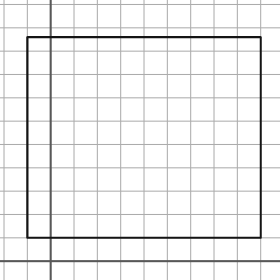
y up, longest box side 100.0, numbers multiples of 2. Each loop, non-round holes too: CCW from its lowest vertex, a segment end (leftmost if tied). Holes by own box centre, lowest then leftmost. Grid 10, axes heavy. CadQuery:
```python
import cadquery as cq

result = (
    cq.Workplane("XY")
    .moveTo(-10.0, 10.0)
    .lineTo(90.0, 10.0)
    .lineTo(90.0, 96.0)
    .lineTo(-10.0, 96.0)
    .close()
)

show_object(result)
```